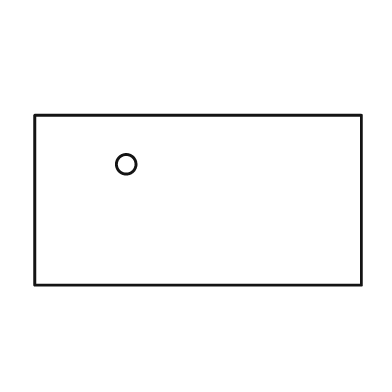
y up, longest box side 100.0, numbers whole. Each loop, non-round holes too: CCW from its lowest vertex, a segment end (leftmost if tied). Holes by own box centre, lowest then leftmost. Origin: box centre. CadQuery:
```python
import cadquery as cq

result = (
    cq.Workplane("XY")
    .moveTo(-50.0, -26.0)
    .lineTo(50.0, -26.0)
    .lineTo(50.0, 26.0)
    .lineTo(-50.0, 26.0)
    .close()
    .moveTo(-22.0, 11.0)
    .circle(3.0)
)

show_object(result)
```